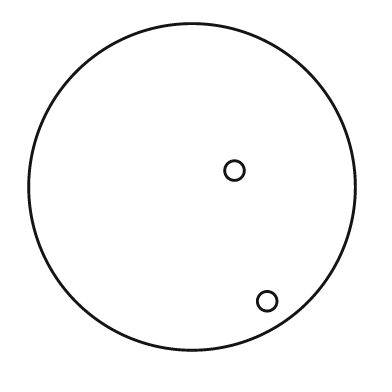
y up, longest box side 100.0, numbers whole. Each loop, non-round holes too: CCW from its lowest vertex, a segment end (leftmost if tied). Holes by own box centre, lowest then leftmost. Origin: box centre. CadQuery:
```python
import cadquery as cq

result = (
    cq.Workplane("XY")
    .moveTo(0.0, 0.0)
    .circle(50.0)
    .moveTo(23.0, -35.0)
    .circle(3.0)
    .moveTo(13.0, 5.0)
    .circle(3.0)
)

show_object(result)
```